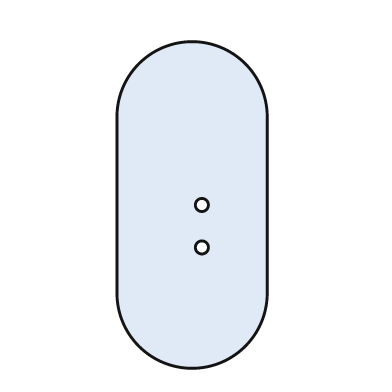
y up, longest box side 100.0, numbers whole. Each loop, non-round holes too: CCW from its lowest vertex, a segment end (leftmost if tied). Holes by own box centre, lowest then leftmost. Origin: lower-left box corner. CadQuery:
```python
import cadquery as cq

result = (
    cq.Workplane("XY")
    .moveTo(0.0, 23.0)
    .threePointArc((23.0, 0.0), (46.0, 23.0))
    .lineTo(46.0, 77.0)
    .threePointArc((23.0, 100.0), (0.0, 77.0))
    .close()
    .moveTo(26.0, 37.0)
    .circle(2.0)
    .moveTo(26.0, 50.0)
    .circle(2.0)
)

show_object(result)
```